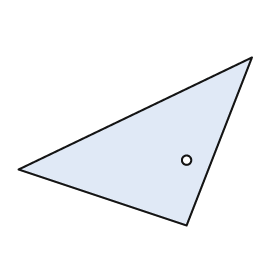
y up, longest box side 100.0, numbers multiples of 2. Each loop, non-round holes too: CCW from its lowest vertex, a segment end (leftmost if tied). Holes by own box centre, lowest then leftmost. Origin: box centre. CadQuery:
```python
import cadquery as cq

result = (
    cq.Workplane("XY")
    .moveTo(22.0, -36.0)
    .lineTo(50.0, 36.0)
    .lineTo(-50.0, -12.0)
    .close()
    .moveTo(22.0, -8.0)
    .circle(2.0)
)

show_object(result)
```